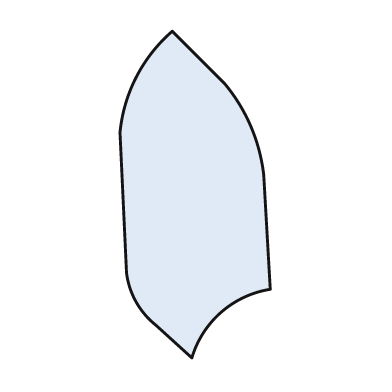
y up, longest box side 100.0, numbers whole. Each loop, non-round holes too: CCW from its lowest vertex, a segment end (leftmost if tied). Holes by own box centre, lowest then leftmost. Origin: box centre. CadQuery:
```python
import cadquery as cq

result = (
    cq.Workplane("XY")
    .moveTo(-1.0, -50.0)
    .threePointArc((8.0, -36.0), (23.0, -29.0))
    .lineTo(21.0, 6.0)
    .threePointArc((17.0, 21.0), (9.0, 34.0))
    .lineTo(-7.0, 50.0)
    .threePointArc((-18.0, 36.0), (-23.0, 19.0))
    .lineTo(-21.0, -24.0)
    .threePointArc((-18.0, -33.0), (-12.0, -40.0))
    .close()
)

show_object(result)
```